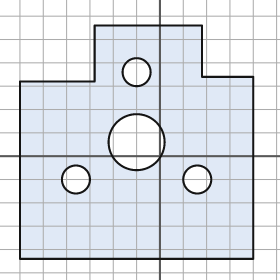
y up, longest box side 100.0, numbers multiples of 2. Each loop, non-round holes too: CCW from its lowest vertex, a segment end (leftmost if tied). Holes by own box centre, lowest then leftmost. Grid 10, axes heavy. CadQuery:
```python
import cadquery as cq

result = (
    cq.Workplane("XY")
    .moveTo(-60.0, -44.0)
    .lineTo(40.0, -44.0)
    .lineTo(40.0, 34.0)
    .lineTo(18.0, 34.0)
    .lineTo(18.0, 56.0)
    .lineTo(-28.0, 56.0)
    .lineTo(-28.0, 32.0)
    .lineTo(-60.0, 32.0)
    .close()
    .moveTo(-36.0, -10.0)
    .circle(6.0)
    .moveTo(16.0, -10.0)
    .circle(6.0)
    .moveTo(-10.0, 6.0)
    .circle(12.0)
    .moveTo(-10.0, 36.0)
    .circle(6.0)
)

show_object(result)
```